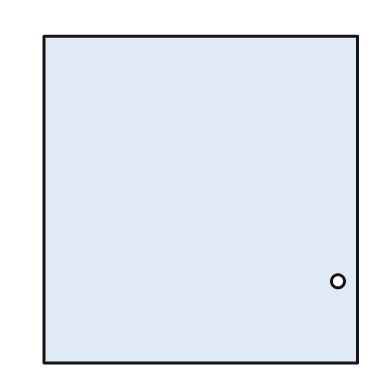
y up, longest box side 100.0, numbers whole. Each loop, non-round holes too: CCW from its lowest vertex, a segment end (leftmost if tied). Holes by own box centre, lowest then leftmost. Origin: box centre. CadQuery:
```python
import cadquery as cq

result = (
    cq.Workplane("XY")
    .moveTo(-48.0, -50.0)
    .lineTo(48.0, -50.0)
    .lineTo(48.0, 50.0)
    .lineTo(-48.0, 50.0)
    .close()
    .moveTo(42.0, -25.0)
    .circle(2.0)
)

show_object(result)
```